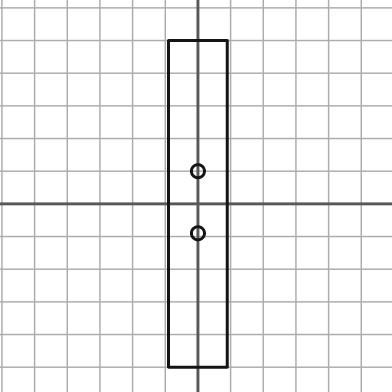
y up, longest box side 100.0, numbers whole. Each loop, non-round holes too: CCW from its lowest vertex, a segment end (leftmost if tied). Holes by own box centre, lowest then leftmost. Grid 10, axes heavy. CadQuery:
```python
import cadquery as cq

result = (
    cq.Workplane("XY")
    .moveTo(-9.0, -50.0)
    .lineTo(9.0, -50.0)
    .lineTo(9.0, 50.0)
    .lineTo(-9.0, 50.0)
    .close()
    .moveTo(0.0, -9.0)
    .circle(2.0)
    .moveTo(0.0, 10.0)
    .circle(2.0)
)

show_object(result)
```